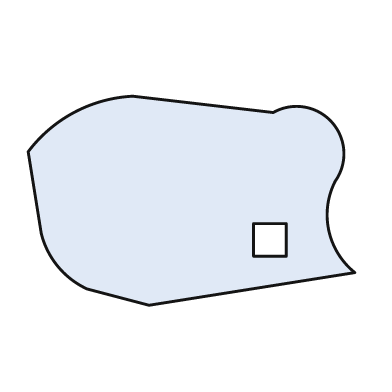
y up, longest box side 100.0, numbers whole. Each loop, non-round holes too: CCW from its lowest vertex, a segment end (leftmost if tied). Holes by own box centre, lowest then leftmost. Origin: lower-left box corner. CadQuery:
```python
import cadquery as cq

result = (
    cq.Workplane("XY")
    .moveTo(37.0, 0.0)
    .lineTo(100.0, 10.0)
    .threePointArc((92.0, 23.0), (94.0, 38.0))
    .threePointArc((93.0, 56.0), (75.0, 59.0))
    .lineTo(32.0, 64.0)
    .threePointArc((14.0, 59.0), (0.0, 47.0))
    .lineTo(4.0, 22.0)
    .threePointArc((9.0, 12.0), (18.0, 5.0))
    .close()
    .moveTo(69.0, 15.0)
    .lineTo(79.0, 15.0)
    .lineTo(79.0, 25.0)
    .lineTo(69.0, 25.0)
    .close()
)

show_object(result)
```